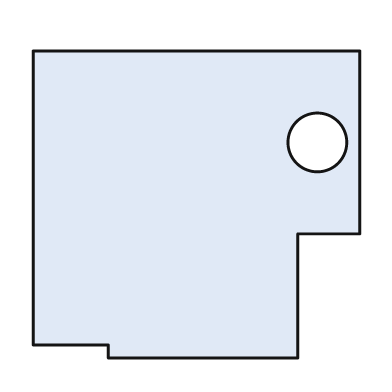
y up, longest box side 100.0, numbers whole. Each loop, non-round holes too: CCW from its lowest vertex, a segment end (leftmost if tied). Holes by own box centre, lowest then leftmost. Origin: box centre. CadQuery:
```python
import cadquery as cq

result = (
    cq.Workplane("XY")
    .moveTo(-27.0, -47.0)
    .lineTo(31.0, -47.0)
    .lineTo(31.0, -9.0)
    .lineTo(50.0, -9.0)
    .lineTo(50.0, 47.0)
    .lineTo(-50.0, 47.0)
    .lineTo(-50.0, -43.0)
    .lineTo(-27.0, -43.0)
    .close()
    .moveTo(37.0, 19.0)
    .circle(9.0)
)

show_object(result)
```